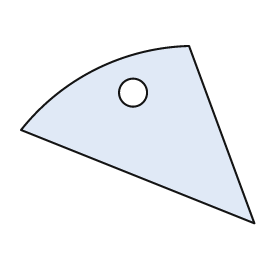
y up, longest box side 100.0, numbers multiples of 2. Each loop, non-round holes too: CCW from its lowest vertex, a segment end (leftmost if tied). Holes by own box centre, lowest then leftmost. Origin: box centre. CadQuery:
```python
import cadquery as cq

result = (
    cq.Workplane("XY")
    .moveTo(50.0, -38.0)
    .lineTo(22.0, 38.0)
    .threePointArc((-18.0, 28.0), (-50.0, 2.0))
    .close()
    .moveTo(-2.0, 18.0)
    .circle(6.0)
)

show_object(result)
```